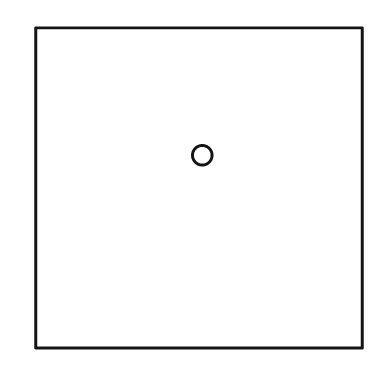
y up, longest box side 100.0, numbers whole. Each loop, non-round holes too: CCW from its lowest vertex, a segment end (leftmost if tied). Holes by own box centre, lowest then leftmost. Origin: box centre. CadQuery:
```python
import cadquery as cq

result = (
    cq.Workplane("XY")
    .moveTo(-50.0, -49.0)
    .lineTo(50.0, -49.0)
    .lineTo(50.0, 49.0)
    .lineTo(-50.0, 49.0)
    .close()
    .moveTo(1.0, 10.0)
    .circle(3.0)
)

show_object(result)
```